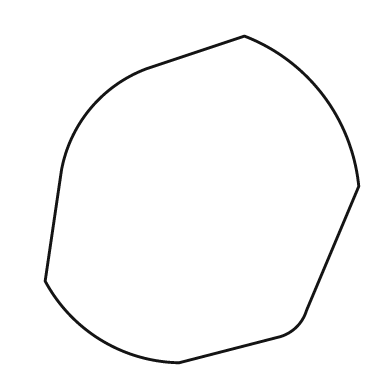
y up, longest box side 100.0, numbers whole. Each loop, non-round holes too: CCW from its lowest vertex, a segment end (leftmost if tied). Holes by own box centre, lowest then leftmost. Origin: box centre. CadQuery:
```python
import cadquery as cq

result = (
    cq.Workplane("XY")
    .moveTo(-7.0, -50.0)
    .lineTo(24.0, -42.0)
    .threePointArc((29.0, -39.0), (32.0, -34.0))
    .lineTo(48.0, 4.0)
    .threePointArc((37.0, 32.0), (13.0, 50.0))
    .lineTo(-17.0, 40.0)
    .threePointArc((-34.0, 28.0), (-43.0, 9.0))
    .lineTo(-48.0, -25.0)
    .threePointArc((-31.0, -43.0), (-7.0, -50.0))
    .close()
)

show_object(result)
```